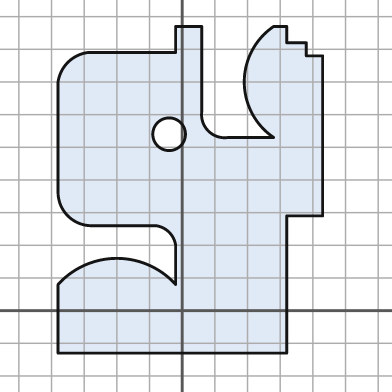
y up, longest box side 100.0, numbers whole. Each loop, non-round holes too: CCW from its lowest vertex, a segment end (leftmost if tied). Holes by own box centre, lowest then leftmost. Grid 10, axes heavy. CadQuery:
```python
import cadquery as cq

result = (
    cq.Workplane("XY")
    .moveTo(-38.0, -13.0)
    .lineTo(32.0, -13.0)
    .lineTo(32.0, 29.0)
    .lineTo(43.0, 29.0)
    .lineTo(43.0, 78.0)
    .lineTo(38.0, 78.0)
    .lineTo(38.0, 82.0)
    .lineTo(32.0, 82.0)
    .lineTo(32.0, 87.0)
    .lineTo(28.0, 87.0)
    .threePointArc((19.0, 70.0), (28.0, 53.0))
    .lineTo(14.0, 53.0)
    .threePointArc((8.0, 55.0), (6.0, 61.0))
    .lineTo(6.0, 87.0)
    .lineTo(-2.0, 87.0)
    .lineTo(-2.0, 79.0)
    .lineTo(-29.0, 79.0)
    .threePointArc((-35.0, 76.0), (-38.0, 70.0))
    .lineTo(-38.0, 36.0)
    .threePointArc((-35.0, 29.0), (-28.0, 26.0))
    .lineTo(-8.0, 26.0)
    .threePointArc((-4.0, 24.0), (-2.0, 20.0))
    .lineTo(-2.0, 8.0)
    .threePointArc((-20.0, 16.0), (-38.0, 8.0))
    .close()
    .moveTo(-4.0, 54.0)
    .circle(5.0)
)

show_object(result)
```